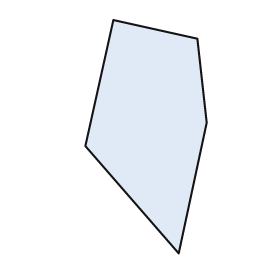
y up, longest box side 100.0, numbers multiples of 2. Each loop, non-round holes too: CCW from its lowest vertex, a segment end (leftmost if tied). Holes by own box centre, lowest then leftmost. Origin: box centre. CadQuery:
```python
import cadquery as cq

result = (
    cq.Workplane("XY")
    .moveTo(14.0, -50.0)
    .lineTo(26.0, 6.0)
    .lineTo(22.0, 42.0)
    .lineTo(-14.0, 50.0)
    .lineTo(-26.0, -4.0)
    .close()
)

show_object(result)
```